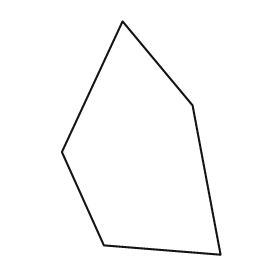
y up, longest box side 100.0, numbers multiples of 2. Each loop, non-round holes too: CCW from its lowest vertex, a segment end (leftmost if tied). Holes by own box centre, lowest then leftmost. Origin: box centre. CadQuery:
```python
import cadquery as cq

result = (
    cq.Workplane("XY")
    .moveTo(34.0, -50.0)
    .lineTo(22.0, 14.0)
    .lineTo(-8.0, 50.0)
    .lineTo(-34.0, -6.0)
    .lineTo(-16.0, -46.0)
    .close()
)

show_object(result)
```